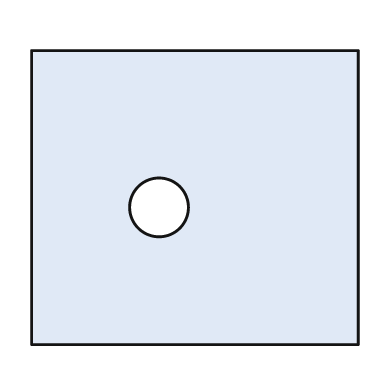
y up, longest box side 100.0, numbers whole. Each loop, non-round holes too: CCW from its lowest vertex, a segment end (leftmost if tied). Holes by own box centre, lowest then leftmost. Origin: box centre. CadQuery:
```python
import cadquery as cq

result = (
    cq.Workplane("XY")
    .moveTo(-50.0, -45.0)
    .lineTo(50.0, -45.0)
    .lineTo(50.0, 45.0)
    .lineTo(-50.0, 45.0)
    .close()
    .moveTo(-11.0, -3.0)
    .circle(9.0)
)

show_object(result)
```